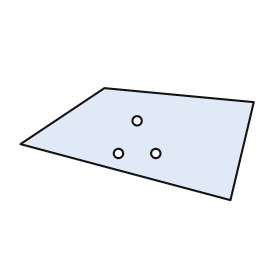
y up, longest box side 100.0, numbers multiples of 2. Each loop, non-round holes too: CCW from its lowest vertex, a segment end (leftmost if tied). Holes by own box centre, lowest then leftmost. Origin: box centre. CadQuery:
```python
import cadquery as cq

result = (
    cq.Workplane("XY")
    .moveTo(40.0, -24.0)
    .lineTo(50.0, 18.0)
    .lineTo(-14.0, 24.0)
    .lineTo(-50.0, 0.0)
    .close()
    .moveTo(-8.0, -4.0)
    .circle(2.0)
    .moveTo(8.0, -4.0)
    .circle(2.0)
    .moveTo(0.0, 10.0)
    .circle(2.0)
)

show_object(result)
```